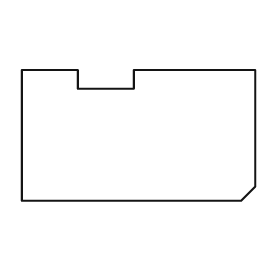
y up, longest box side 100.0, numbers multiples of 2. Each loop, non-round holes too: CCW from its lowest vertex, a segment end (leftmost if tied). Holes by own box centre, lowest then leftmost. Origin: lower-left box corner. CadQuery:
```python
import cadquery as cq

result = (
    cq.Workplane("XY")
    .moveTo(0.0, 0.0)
    .lineTo(94.0, 0.0)
    .lineTo(100.0, 6.0)
    .lineTo(100.0, 56.0)
    .lineTo(48.0, 56.0)
    .lineTo(48.0, 48.0)
    .lineTo(24.0, 48.0)
    .lineTo(24.0, 56.0)
    .lineTo(0.0, 56.0)
    .close()
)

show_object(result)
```